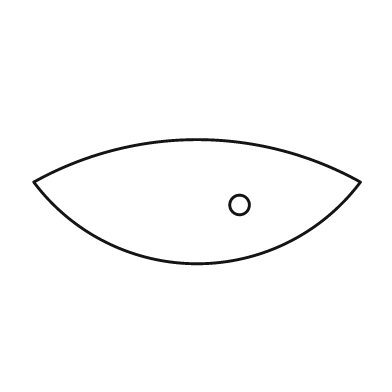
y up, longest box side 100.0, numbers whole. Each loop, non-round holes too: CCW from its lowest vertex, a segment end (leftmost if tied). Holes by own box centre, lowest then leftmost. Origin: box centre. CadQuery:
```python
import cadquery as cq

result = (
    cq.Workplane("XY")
    .moveTo(-50.0, 6.0)
    .threePointArc((0.0, -19.0), (50.0, 6.0))
    .threePointArc((0.0, 19.0), (-50.0, 6.0))
    .close()
    .moveTo(13.0, -1.0)
    .circle(3.0)
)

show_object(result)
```